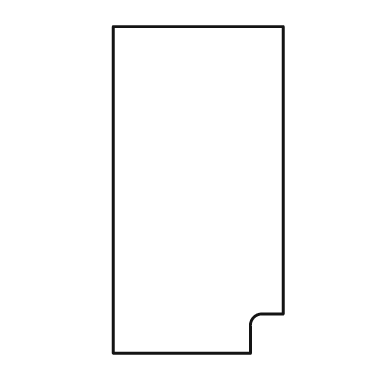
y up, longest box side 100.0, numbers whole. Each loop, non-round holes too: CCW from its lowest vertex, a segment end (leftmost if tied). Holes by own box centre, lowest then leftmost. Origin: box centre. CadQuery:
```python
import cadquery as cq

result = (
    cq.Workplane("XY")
    .moveTo(-26.0, -50.0)
    .lineTo(16.0, -50.0)
    .lineTo(16.0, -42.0)
    .threePointArc((17.0, -39.0), (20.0, -38.0))
    .lineTo(26.0, -38.0)
    .lineTo(26.0, 50.0)
    .lineTo(-26.0, 50.0)
    .close()
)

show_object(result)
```